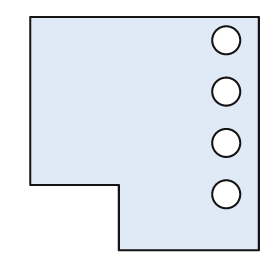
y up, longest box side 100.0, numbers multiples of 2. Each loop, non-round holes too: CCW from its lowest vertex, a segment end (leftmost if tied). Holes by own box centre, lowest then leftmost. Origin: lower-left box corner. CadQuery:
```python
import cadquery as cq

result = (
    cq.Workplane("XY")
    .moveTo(38.0, 0.0)
    .lineTo(98.0, 0.0)
    .lineTo(98.0, 100.0)
    .lineTo(0.0, 100.0)
    .lineTo(0.0, 28.0)
    .lineTo(38.0, 28.0)
    .close()
    .moveTo(84.0, 24.0)
    .circle(6.0)
    .moveTo(84.0, 46.0)
    .circle(6.0)
    .moveTo(84.0, 68.0)
    .circle(6.0)
    .moveTo(84.0, 90.0)
    .circle(6.0)
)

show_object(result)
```